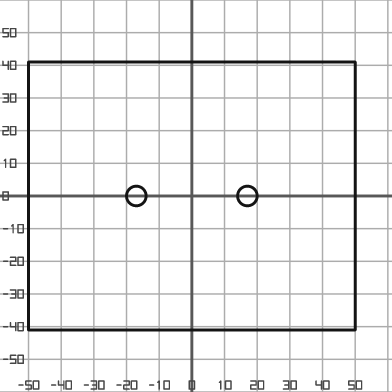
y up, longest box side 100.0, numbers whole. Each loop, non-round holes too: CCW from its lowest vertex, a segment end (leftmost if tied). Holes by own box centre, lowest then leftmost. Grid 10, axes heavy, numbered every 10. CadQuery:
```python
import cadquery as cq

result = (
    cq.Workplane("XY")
    .moveTo(-50.0, -41.0)
    .lineTo(50.0, -41.0)
    .lineTo(50.0, 41.0)
    .lineTo(-50.0, 41.0)
    .close()
    .moveTo(-17.0, 0.0)
    .circle(3.0)
    .moveTo(17.0, 0.0)
    .circle(3.0)
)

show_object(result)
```